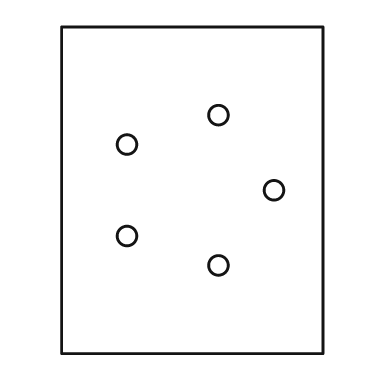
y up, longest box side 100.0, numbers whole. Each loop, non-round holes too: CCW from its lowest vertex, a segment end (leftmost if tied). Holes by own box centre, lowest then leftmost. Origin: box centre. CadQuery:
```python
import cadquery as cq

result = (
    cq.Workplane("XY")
    .moveTo(-40.0, -50.0)
    .lineTo(40.0, -50.0)
    .lineTo(40.0, 50.0)
    .lineTo(-40.0, 50.0)
    .close()
    .moveTo(8.0, -23.0)
    .circle(3.0)
    .moveTo(-20.0, -14.0)
    .circle(3.0)
    .moveTo(25.0, 0.0)
    .circle(3.0)
    .moveTo(-20.0, 14.0)
    .circle(3.0)
    .moveTo(8.0, 23.0)
    .circle(3.0)
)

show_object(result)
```